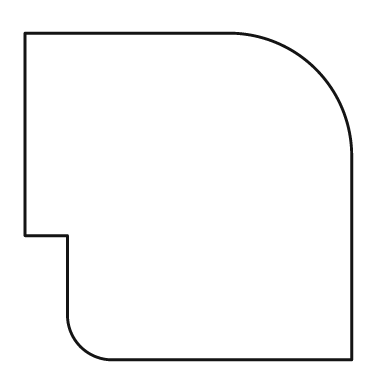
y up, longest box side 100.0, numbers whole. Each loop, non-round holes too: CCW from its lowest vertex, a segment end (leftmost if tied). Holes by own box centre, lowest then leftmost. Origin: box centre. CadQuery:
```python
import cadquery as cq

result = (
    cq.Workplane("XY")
    .moveTo(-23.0, -50.0)
    .lineTo(50.0, -50.0)
    .lineTo(50.0, 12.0)
    .threePointArc((39.0, 39.0), (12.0, 50.0))
    .lineTo(-50.0, 50.0)
    .lineTo(-50.0, -12.0)
    .lineTo(-37.0, -12.0)
    .lineTo(-37.0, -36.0)
    .threePointArc((-33.0, -46.0), (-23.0, -50.0))
    .close()
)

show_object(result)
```